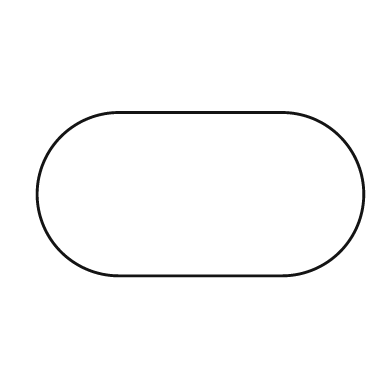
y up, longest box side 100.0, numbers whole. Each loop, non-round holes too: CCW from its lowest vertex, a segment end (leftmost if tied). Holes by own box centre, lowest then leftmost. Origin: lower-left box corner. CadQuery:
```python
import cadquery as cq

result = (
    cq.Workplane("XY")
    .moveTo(25.0, 0.0)
    .lineTo(75.0, 0.0)
    .threePointArc((100.0, 25.0), (75.0, 50.0))
    .lineTo(25.0, 50.0)
    .threePointArc((0.0, 25.0), (25.0, 0.0))
    .close()
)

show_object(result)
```